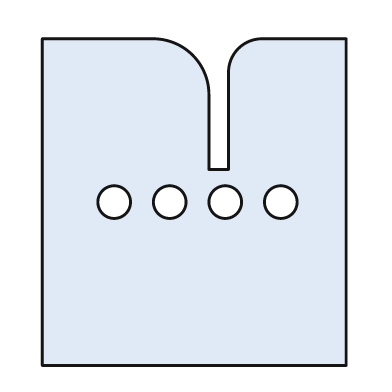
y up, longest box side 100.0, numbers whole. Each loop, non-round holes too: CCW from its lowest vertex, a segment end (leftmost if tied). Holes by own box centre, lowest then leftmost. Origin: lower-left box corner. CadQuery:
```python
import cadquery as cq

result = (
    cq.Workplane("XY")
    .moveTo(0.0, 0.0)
    .lineTo(93.0, 0.0)
    .lineTo(93.0, 100.0)
    .lineTo(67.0, 100.0)
    .threePointArc((60.0, 97.0), (57.0, 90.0))
    .lineTo(57.0, 60.0)
    .lineTo(51.0, 60.0)
    .lineTo(51.0, 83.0)
    .threePointArc((46.0, 95.0), (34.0, 100.0))
    .lineTo(0.0, 100.0)
    .close()
    .moveTo(22.0, 50.0)
    .circle(5.0)
    .moveTo(39.0, 50.0)
    .circle(5.0)
    .moveTo(56.0, 50.0)
    .circle(5.0)
    .moveTo(73.0, 50.0)
    .circle(5.0)
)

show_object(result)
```